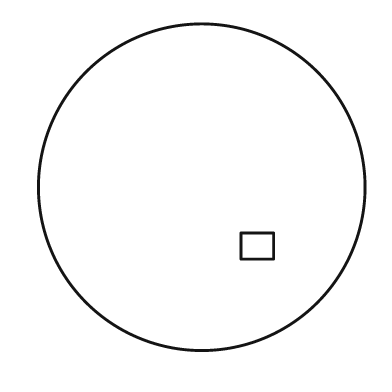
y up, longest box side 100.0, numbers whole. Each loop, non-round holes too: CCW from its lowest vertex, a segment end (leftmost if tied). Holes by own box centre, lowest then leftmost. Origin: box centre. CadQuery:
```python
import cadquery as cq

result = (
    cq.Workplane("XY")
    .moveTo(0.0, 0.0)
    .circle(50.0)
    .moveTo(12.0, -22.0)
    .lineTo(22.0, -22.0)
    .lineTo(22.0, -14.0)
    .lineTo(12.0, -14.0)
    .close()
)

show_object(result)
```